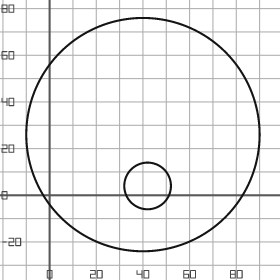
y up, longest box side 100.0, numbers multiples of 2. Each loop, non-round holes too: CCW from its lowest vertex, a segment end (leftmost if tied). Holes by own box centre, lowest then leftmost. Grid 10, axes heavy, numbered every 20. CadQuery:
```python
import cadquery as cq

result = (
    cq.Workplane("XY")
    .moveTo(40.0, 26.0)
    .circle(50.0)
    .moveTo(42.0, 4.0)
    .circle(10.0)
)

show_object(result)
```